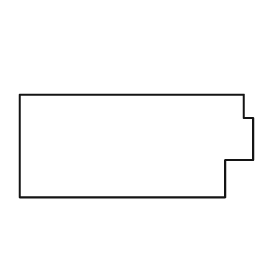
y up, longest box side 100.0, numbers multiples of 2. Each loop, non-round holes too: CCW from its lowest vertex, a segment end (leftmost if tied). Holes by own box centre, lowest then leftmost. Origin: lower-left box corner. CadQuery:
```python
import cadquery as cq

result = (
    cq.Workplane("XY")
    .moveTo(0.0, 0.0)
    .lineTo(88.0, 0.0)
    .lineTo(88.0, 16.0)
    .lineTo(100.0, 16.0)
    .lineTo(100.0, 34.0)
    .lineTo(96.0, 34.0)
    .lineTo(96.0, 44.0)
    .lineTo(0.0, 44.0)
    .close()
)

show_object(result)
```